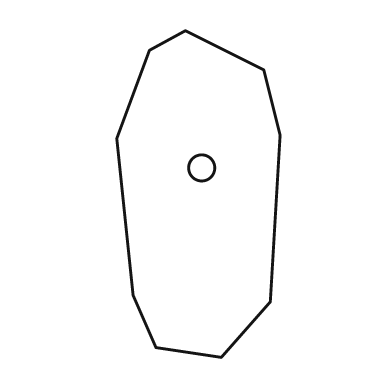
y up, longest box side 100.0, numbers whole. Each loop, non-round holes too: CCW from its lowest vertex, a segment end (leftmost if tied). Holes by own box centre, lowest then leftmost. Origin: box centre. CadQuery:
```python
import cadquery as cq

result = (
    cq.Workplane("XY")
    .moveTo(7.0, -50.0)
    .lineTo(22.0, -33.0)
    .lineTo(25.0, 18.0)
    .lineTo(20.0, 38.0)
    .lineTo(-4.0, 50.0)
    .lineTo(-15.0, 44.0)
    .lineTo(-25.0, 17.0)
    .lineTo(-20.0, -31.0)
    .lineTo(-13.0, -47.0)
    .close()
    .moveTo(1.0, 8.0)
    .circle(4.0)
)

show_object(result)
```